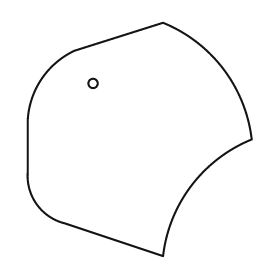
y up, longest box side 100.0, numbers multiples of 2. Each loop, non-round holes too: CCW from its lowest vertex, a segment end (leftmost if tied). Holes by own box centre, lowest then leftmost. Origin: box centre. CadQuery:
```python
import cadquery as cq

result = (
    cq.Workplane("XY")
    .moveTo(10.0, -50.0)
    .threePointArc((22.0, -20.0), (48.0, 0.0))
    .threePointArc((36.0, 30.0), (10.0, 50.0))
    .lineTo(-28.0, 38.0)
    .threePointArc((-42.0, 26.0), (-48.0, 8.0))
    .lineTo(-48.0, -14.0)
    .threePointArc((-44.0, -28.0), (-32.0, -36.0))
    .close()
    .moveTo(-20.0, 24.0)
    .circle(2.0)
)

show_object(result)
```